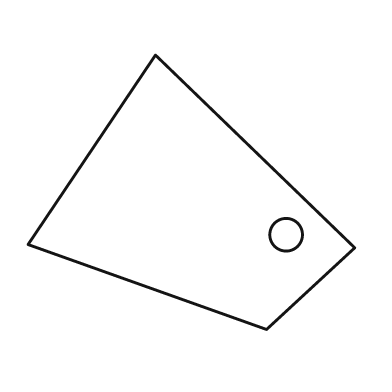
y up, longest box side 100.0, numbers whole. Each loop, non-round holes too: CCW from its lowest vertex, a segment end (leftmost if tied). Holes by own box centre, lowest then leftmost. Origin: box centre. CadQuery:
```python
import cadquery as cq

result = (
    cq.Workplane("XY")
    .moveTo(23.0, -42.0)
    .lineTo(50.0, -17.0)
    .lineTo(-11.0, 42.0)
    .lineTo(-50.0, -16.0)
    .close()
    .moveTo(29.0, -13.0)
    .circle(5.0)
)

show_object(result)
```